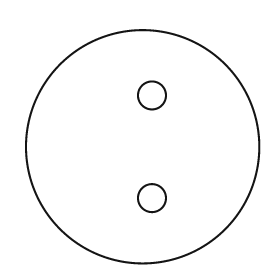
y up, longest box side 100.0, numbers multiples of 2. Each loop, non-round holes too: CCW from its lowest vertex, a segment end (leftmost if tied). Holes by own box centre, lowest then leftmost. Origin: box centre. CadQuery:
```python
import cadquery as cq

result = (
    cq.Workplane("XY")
    .moveTo(0.0, 0.0)
    .circle(50.0)
    .moveTo(4.0, -22.0)
    .circle(6.0)
    .moveTo(4.0, 22.0)
    .circle(6.0)
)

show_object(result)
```